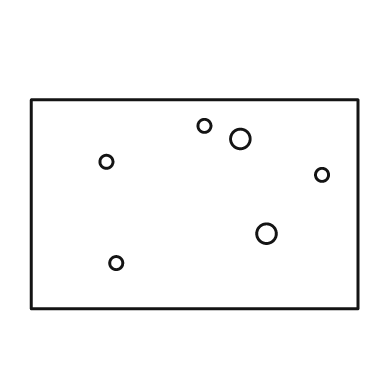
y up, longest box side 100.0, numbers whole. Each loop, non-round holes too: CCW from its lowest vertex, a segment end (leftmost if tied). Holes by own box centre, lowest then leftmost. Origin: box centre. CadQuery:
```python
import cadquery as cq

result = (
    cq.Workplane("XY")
    .moveTo(-50.0, -32.0)
    .lineTo(50.0, -32.0)
    .lineTo(50.0, 32.0)
    .lineTo(-50.0, 32.0)
    .close()
    .moveTo(-24.0, -18.0)
    .circle(2.0)
    .moveTo(22.0, -9.0)
    .circle(3.0)
    .moveTo(39.0, 9.0)
    .circle(2.0)
    .moveTo(-27.0, 13.0)
    .circle(2.0)
    .moveTo(14.0, 20.0)
    .circle(3.0)
    .moveTo(3.0, 24.0)
    .circle(2.0)
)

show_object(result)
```